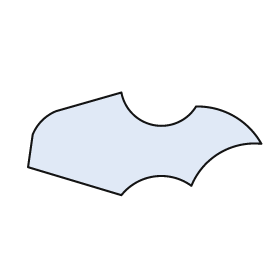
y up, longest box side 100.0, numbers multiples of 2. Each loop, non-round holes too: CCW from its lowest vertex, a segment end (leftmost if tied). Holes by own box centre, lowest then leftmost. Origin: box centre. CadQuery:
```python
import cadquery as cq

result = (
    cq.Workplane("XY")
    .moveTo(-10.0, -22.0)
    .threePointArc((4.0, -14.0), (20.0, -18.0))
    .threePointArc((32.0, -4.0), (50.0, 0.0))
    .threePointArc((38.0, 12.0), (22.0, 16.0))
    .threePointArc((4.0, 8.0), (-10.0, 22.0))
    .lineTo(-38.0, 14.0)
    .threePointArc((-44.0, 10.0), (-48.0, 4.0))
    .lineTo(-50.0, -10.0)
    .close()
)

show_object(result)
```